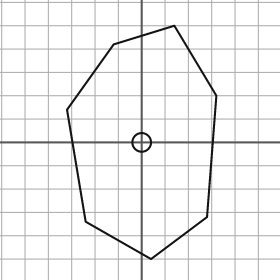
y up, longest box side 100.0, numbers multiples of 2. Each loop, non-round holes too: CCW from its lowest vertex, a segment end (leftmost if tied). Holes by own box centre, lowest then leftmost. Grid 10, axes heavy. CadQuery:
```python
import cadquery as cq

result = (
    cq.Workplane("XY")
    .moveTo(4.0, -50.0)
    .lineTo(28.0, -32.0)
    .lineTo(32.0, 20.0)
    .lineTo(14.0, 50.0)
    .lineTo(-12.0, 42.0)
    .lineTo(-32.0, 14.0)
    .lineTo(-24.0, -34.0)
    .close()
    .moveTo(0.0, 0.0)
    .circle(4.0)
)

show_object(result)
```